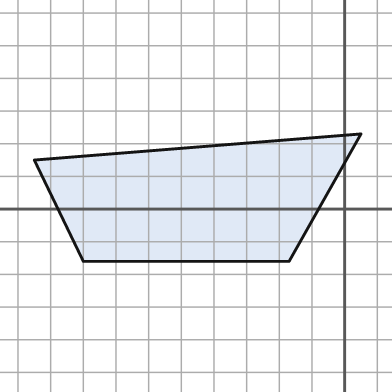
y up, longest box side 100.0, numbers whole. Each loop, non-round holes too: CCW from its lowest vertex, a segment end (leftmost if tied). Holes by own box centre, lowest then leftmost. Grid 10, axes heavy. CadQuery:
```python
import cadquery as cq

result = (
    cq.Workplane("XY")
    .moveTo(-80.0, -16.0)
    .lineTo(-17.0, -16.0)
    .lineTo(5.0, 23.0)
    .lineTo(-95.0, 15.0)
    .close()
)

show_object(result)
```